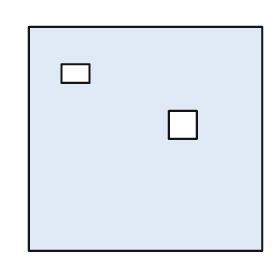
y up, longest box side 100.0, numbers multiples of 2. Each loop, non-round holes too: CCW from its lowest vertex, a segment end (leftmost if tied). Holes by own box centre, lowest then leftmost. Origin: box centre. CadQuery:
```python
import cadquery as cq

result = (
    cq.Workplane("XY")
    .moveTo(-50.0, -48.0)
    .lineTo(50.0, -48.0)
    .lineTo(50.0, 48.0)
    .lineTo(-50.0, 48.0)
    .close()
    .moveTo(10.0, 0.0)
    .lineTo(22.0, 0.0)
    .lineTo(22.0, 12.0)
    .lineTo(10.0, 12.0)
    .close()
    .moveTo(-36.0, 24.0)
    .lineTo(-24.0, 24.0)
    .lineTo(-24.0, 32.0)
    .lineTo(-36.0, 32.0)
    .close()
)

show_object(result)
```